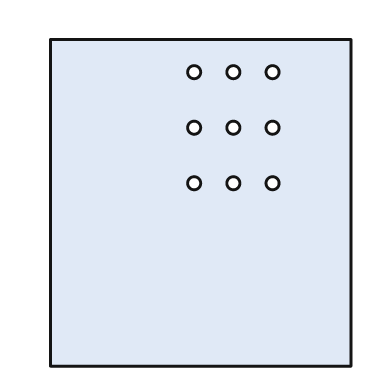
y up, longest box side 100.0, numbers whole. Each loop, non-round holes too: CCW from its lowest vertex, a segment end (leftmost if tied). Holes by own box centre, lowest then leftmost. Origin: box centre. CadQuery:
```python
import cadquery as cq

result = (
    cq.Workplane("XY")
    .moveTo(-46.0, -50.0)
    .lineTo(46.0, -50.0)
    .lineTo(46.0, 50.0)
    .lineTo(-46.0, 50.0)
    .close()
    .moveTo(-2.0, 6.0)
    .circle(2.0)
    .moveTo(10.0, 6.0)
    .circle(2.0)
    .moveTo(22.0, 6.0)
    .circle(2.0)
    .moveTo(-2.0, 23.0)
    .circle(2.0)
    .moveTo(10.0, 23.0)
    .circle(2.0)
    .moveTo(22.0, 23.0)
    .circle(2.0)
    .moveTo(-2.0, 40.0)
    .circle(2.0)
    .moveTo(10.0, 40.0)
    .circle(2.0)
    .moveTo(22.0, 40.0)
    .circle(2.0)
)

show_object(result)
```